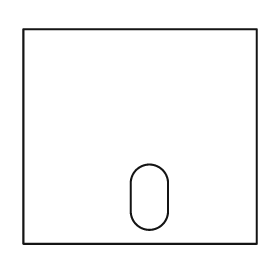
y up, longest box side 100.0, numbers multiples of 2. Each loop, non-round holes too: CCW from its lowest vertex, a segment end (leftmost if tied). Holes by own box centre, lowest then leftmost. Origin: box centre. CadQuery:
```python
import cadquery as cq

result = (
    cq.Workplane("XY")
    .moveTo(-50.0, -46.0)
    .lineTo(50.0, -46.0)
    .lineTo(50.0, 46.0)
    .lineTo(-50.0, 46.0)
    .close()
    .moveTo(-4.0, -32.0)
    .threePointArc((4.0, -40.0), (12.0, -32.0))
    .lineTo(12.0, -20.0)
    .threePointArc((4.0, -12.0), (-4.0, -20.0))
    .close()
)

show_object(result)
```